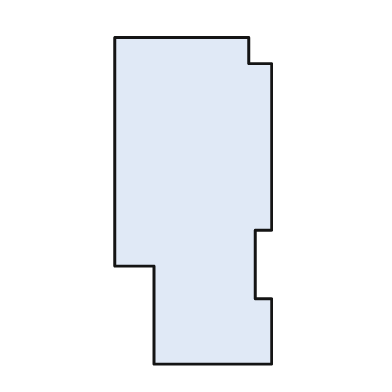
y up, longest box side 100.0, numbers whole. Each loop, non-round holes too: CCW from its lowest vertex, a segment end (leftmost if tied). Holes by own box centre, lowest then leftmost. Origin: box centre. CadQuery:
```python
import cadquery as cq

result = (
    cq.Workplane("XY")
    .moveTo(-12.0, -50.0)
    .lineTo(24.0, -50.0)
    .lineTo(24.0, -30.0)
    .lineTo(19.0, -30.0)
    .lineTo(19.0, -9.0)
    .lineTo(24.0, -9.0)
    .lineTo(24.0, 42.0)
    .lineTo(17.0, 42.0)
    .lineTo(17.0, 50.0)
    .lineTo(-24.0, 50.0)
    .lineTo(-24.0, -20.0)
    .lineTo(-12.0, -20.0)
    .close()
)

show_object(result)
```